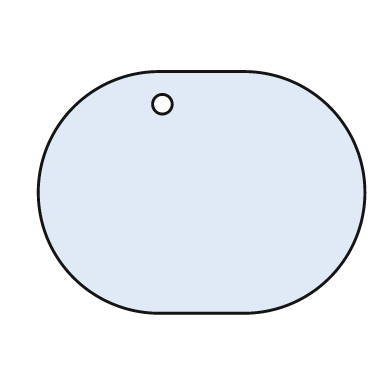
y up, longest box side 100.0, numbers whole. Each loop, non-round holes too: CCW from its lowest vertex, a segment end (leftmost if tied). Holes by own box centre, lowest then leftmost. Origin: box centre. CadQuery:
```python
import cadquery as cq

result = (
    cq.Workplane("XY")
    .moveTo(-13.0, -37.0)
    .lineTo(13.0, -37.0)
    .threePointArc((50.0, 0.0), (13.0, 37.0))
    .lineTo(-13.0, 37.0)
    .threePointArc((-50.0, 0.0), (-13.0, -37.0))
    .close()
    .moveTo(-12.0, 27.0)
    .circle(3.0)
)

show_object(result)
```